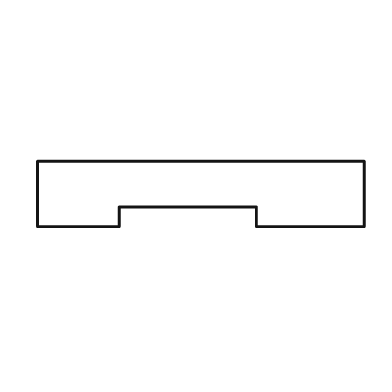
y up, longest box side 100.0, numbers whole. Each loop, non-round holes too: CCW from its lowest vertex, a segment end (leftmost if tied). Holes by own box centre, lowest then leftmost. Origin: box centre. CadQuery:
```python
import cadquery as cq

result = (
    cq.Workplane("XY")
    .moveTo(-50.0, -10.0)
    .lineTo(-25.0, -10.0)
    .lineTo(-25.0, -4.0)
    .lineTo(17.0, -4.0)
    .lineTo(17.0, -10.0)
    .lineTo(50.0, -10.0)
    .lineTo(50.0, 10.0)
    .lineTo(-50.0, 10.0)
    .close()
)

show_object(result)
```